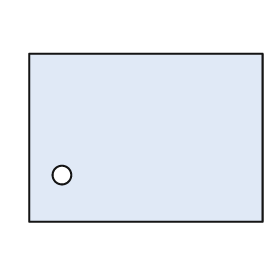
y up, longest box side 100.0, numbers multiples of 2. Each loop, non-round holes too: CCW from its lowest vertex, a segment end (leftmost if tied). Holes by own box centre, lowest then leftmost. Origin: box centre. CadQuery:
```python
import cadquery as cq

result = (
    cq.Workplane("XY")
    .moveTo(-50.0, -36.0)
    .lineTo(50.0, -36.0)
    .lineTo(50.0, 36.0)
    .lineTo(-50.0, 36.0)
    .close()
    .moveTo(-36.0, -16.0)
    .circle(4.0)
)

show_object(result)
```